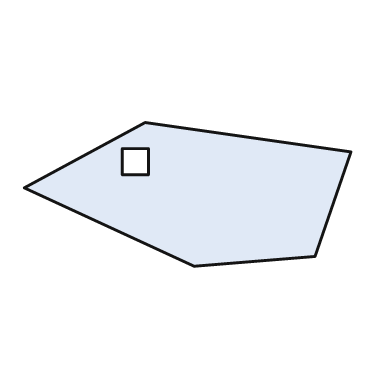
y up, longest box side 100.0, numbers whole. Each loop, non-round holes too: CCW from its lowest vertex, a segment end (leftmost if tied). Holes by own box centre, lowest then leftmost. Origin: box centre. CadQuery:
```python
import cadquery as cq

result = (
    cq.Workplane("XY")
    .moveTo(2.0, -22.0)
    .lineTo(39.0, -19.0)
    .lineTo(50.0, 13.0)
    .lineTo(-13.0, 22.0)
    .lineTo(-50.0, 2.0)
    .close()
    .moveTo(-20.0, 6.0)
    .lineTo(-12.0, 6.0)
    .lineTo(-12.0, 14.0)
    .lineTo(-20.0, 14.0)
    .close()
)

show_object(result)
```